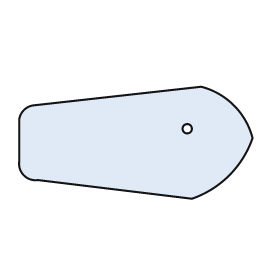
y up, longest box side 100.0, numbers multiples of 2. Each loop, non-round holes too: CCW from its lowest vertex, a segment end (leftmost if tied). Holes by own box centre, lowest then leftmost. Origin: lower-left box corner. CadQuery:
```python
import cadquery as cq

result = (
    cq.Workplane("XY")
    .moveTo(74.0, 0.0)
    .threePointArc((90.0, 10.0), (100.0, 26.0))
    .threePointArc((92.0, 40.0), (78.0, 48.0))
    .lineTo(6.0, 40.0)
    .threePointArc((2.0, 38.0), (0.0, 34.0))
    .lineTo(0.0, 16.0)
    .threePointArc((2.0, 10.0), (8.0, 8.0))
    .close()
    .moveTo(72.0, 30.0)
    .circle(2.0)
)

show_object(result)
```